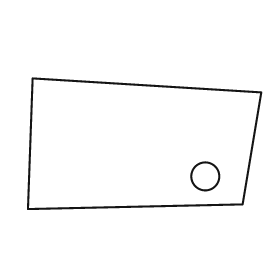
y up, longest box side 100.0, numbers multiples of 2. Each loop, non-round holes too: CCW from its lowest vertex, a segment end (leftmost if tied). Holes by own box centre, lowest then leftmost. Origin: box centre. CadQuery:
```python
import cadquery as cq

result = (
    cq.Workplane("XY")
    .moveTo(-50.0, -28.0)
    .lineTo(42.0, -26.0)
    .lineTo(50.0, 22.0)
    .lineTo(-48.0, 28.0)
    .close()
    .moveTo(26.0, -14.0)
    .circle(6.0)
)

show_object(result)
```